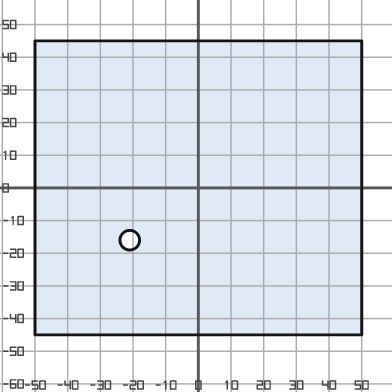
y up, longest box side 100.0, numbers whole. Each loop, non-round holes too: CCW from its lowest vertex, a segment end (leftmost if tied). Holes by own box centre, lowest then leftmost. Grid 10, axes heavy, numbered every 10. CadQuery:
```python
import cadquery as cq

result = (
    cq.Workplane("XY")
    .moveTo(-50.0, -45.0)
    .lineTo(50.0, -45.0)
    .lineTo(50.0, 45.0)
    .lineTo(-50.0, 45.0)
    .close()
    .moveTo(-21.0, -16.0)
    .circle(3.0)
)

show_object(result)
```